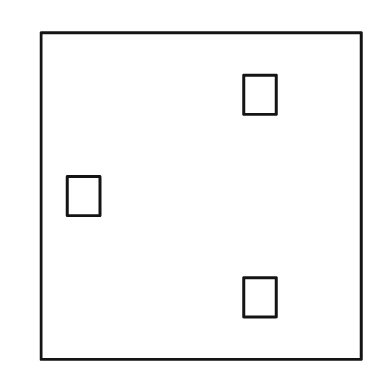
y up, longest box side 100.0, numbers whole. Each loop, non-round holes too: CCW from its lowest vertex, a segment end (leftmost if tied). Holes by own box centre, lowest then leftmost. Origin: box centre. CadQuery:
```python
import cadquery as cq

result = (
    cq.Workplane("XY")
    .moveTo(-49.0, -50.0)
    .lineTo(49.0, -50.0)
    .lineTo(49.0, 50.0)
    .lineTo(-49.0, 50.0)
    .close()
    .moveTo(13.0, -37.0)
    .lineTo(23.0, -37.0)
    .lineTo(23.0, -25.0)
    .lineTo(13.0, -25.0)
    .close()
    .moveTo(-41.0, -6.0)
    .lineTo(-31.0, -6.0)
    .lineTo(-31.0, 6.0)
    .lineTo(-41.0, 6.0)
    .close()
    .moveTo(13.0, 25.0)
    .lineTo(23.0, 25.0)
    .lineTo(23.0, 37.0)
    .lineTo(13.0, 37.0)
    .close()
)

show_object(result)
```